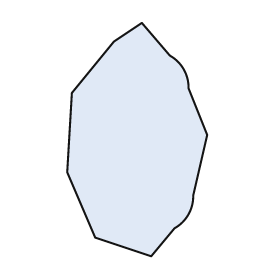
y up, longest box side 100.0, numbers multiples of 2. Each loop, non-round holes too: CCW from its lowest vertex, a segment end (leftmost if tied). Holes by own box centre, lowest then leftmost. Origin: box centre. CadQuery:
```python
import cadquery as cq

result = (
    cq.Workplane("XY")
    .moveTo(6.0, -50.0)
    .lineTo(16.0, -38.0)
    .threePointArc((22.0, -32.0), (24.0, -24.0))
    .lineTo(30.0, 2.0)
    .lineTo(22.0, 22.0)
    .threePointArc((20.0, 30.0), (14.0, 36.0))
    .lineTo(2.0, 50.0)
    .lineTo(-10.0, 42.0)
    .lineTo(-28.0, 20.0)
    .lineTo(-30.0, -14.0)
    .lineTo(-18.0, -42.0)
    .close()
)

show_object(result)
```